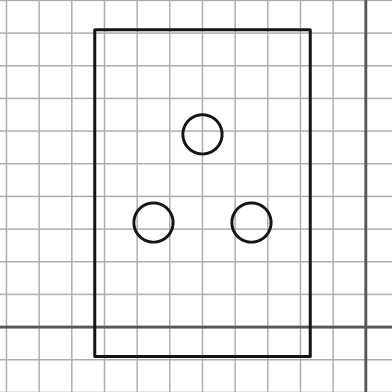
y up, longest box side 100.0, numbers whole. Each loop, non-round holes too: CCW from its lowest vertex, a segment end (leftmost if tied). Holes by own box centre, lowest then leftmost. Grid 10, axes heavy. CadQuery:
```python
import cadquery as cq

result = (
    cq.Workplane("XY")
    .moveTo(-83.0, -9.0)
    .lineTo(-17.0, -9.0)
    .lineTo(-17.0, 91.0)
    .lineTo(-83.0, 91.0)
    .close()
    .moveTo(-65.0, 32.0)
    .circle(6.0)
    .moveTo(-35.0, 32.0)
    .circle(6.0)
    .moveTo(-50.0, 59.0)
    .circle(6.0)
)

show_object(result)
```